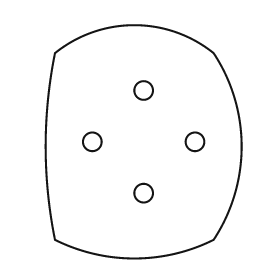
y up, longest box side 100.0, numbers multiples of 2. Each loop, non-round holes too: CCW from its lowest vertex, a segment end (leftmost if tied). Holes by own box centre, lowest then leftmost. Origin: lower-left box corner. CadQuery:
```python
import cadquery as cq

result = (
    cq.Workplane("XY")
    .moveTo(4.0, 8.0)
    .threePointArc((38.0, 0.0), (72.0, 8.0))
    .threePointArc((84.0, 48.0), (72.0, 88.0))
    .threePointArc((38.0, 100.0), (4.0, 88.0))
    .threePointArc((0.0, 48.0), (4.0, 8.0))
    .close()
    .moveTo(42.0, 28.0)
    .circle(4.0)
    .moveTo(20.0, 50.0)
    .circle(4.0)
    .moveTo(64.0, 50.0)
    .circle(4.0)
    .moveTo(42.0, 72.0)
    .circle(4.0)
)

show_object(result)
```